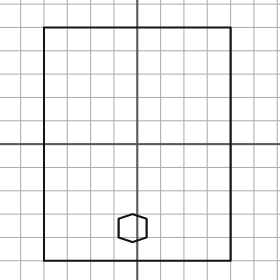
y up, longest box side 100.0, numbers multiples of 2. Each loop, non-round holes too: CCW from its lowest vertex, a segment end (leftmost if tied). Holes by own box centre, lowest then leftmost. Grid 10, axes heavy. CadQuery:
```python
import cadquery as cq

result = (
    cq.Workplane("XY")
    .moveTo(-40.0, -50.0)
    .lineTo(40.0, -50.0)
    .lineTo(40.0, 50.0)
    .lineTo(-40.0, 50.0)
    .close()
    .moveTo(-2.0, -42.0)
    .lineTo(4.0, -40.0)
    .lineTo(4.0, -32.0)
    .lineTo(-2.0, -30.0)
    .lineTo(-8.0, -32.0)
    .lineTo(-8.0, -40.0)
    .close()
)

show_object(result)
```